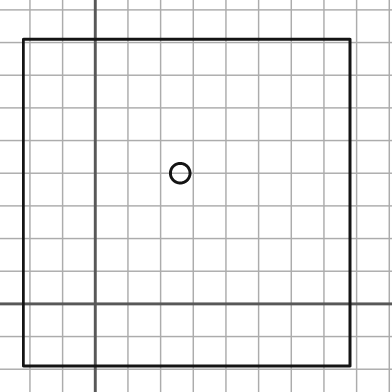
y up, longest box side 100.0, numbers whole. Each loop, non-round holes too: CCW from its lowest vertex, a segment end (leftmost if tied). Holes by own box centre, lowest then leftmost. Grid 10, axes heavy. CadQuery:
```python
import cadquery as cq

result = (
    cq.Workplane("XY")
    .moveTo(-22.0, -19.0)
    .lineTo(78.0, -19.0)
    .lineTo(78.0, 81.0)
    .lineTo(-22.0, 81.0)
    .close()
    .moveTo(26.0, 40.0)
    .circle(3.0)
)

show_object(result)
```